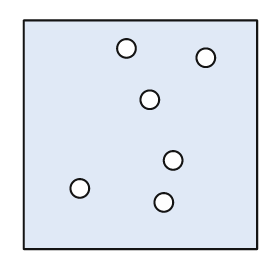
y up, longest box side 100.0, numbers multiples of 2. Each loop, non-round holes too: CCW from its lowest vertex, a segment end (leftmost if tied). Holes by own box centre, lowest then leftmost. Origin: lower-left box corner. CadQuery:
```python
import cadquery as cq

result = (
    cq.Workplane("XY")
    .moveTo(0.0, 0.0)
    .lineTo(100.0, 0.0)
    .lineTo(100.0, 98.0)
    .lineTo(0.0, 98.0)
    .close()
    .moveTo(60.0, 20.0)
    .circle(4.0)
    .moveTo(24.0, 26.0)
    .circle(4.0)
    .moveTo(64.0, 38.0)
    .circle(4.0)
    .moveTo(54.0, 64.0)
    .circle(4.0)
    .moveTo(78.0, 82.0)
    .circle(4.0)
    .moveTo(44.0, 86.0)
    .circle(4.0)
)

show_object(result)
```